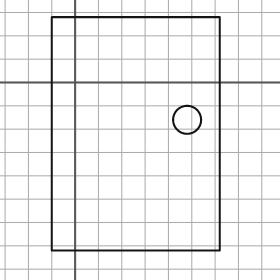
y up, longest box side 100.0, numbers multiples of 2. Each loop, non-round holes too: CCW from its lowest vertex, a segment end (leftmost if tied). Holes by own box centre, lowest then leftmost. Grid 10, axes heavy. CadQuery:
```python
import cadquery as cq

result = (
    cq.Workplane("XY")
    .moveTo(-10.0, -72.0)
    .lineTo(62.0, -72.0)
    .lineTo(62.0, 28.0)
    .lineTo(-10.0, 28.0)
    .close()
    .moveTo(48.0, -16.0)
    .circle(6.0)
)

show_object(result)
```